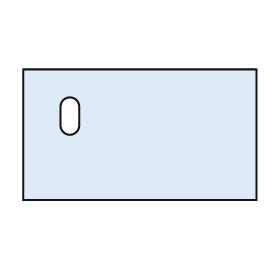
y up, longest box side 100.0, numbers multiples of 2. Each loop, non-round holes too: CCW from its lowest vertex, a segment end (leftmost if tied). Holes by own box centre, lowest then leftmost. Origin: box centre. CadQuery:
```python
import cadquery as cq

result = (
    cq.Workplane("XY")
    .moveTo(-50.0, -28.0)
    .lineTo(50.0, -28.0)
    .lineTo(50.0, 28.0)
    .lineTo(-50.0, 28.0)
    .close()
    .moveTo(-34.0, 4.0)
    .threePointArc((-30.0, 0.0), (-26.0, 4.0))
    .lineTo(-26.0, 12.0)
    .threePointArc((-30.0, 16.0), (-34.0, 12.0))
    .close()
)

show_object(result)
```